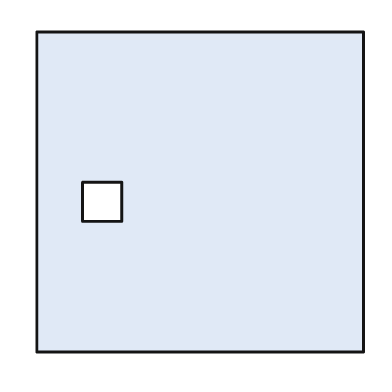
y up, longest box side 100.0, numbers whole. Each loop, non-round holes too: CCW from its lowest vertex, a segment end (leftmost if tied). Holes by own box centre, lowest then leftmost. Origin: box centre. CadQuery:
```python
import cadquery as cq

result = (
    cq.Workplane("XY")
    .moveTo(-50.0, -49.0)
    .lineTo(50.0, -49.0)
    .lineTo(50.0, 49.0)
    .lineTo(-50.0, 49.0)
    .close()
    .moveTo(-36.0, -9.0)
    .lineTo(-24.0, -9.0)
    .lineTo(-24.0, 3.0)
    .lineTo(-36.0, 3.0)
    .close()
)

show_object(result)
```